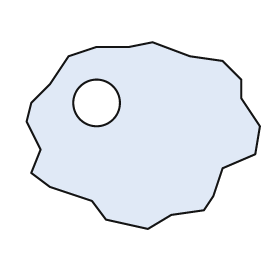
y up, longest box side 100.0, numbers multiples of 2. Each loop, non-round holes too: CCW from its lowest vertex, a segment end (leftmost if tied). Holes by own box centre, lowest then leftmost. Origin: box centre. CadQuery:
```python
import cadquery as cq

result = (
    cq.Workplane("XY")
    .moveTo(2.0, -40.0)
    .lineTo(12.0, -34.0)
    .lineTo(26.0, -32.0)
    .lineTo(30.0, -26.0)
    .lineTo(34.0, -14.0)
    .lineTo(48.0, -8.0)
    .lineTo(50.0, 4.0)
    .lineTo(42.0, 16.0)
    .lineTo(42.0, 24.0)
    .lineTo(34.0, 32.0)
    .lineTo(20.0, 34.0)
    .lineTo(4.0, 40.0)
    .lineTo(-6.0, 38.0)
    .lineTo(-20.0, 38.0)
    .lineTo(-32.0, 34.0)
    .lineTo(-40.0, 22.0)
    .lineTo(-48.0, 14.0)
    .lineTo(-50.0, 6.0)
    .lineTo(-44.0, -6.0)
    .lineTo(-48.0, -16.0)
    .lineTo(-40.0, -22.0)
    .lineTo(-22.0, -28.0)
    .lineTo(-16.0, -36.0)
    .close()
    .moveTo(-20.0, 14.0)
    .circle(10.0)
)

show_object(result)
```